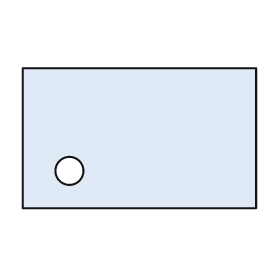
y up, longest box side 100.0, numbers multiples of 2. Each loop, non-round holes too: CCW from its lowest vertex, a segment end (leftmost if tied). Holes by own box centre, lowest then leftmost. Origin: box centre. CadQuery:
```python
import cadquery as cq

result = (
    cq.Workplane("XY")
    .moveTo(-50.0, -30.0)
    .lineTo(50.0, -30.0)
    .lineTo(50.0, 30.0)
    .lineTo(-50.0, 30.0)
    .close()
    .moveTo(-30.0, -14.0)
    .circle(6.0)
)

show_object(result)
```